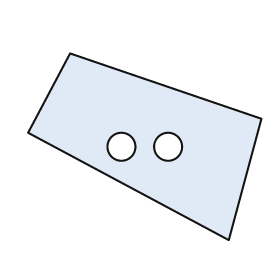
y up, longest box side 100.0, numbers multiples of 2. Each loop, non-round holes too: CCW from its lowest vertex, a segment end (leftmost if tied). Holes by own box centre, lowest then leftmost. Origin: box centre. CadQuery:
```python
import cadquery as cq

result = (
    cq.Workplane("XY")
    .moveTo(36.0, -40.0)
    .lineTo(50.0, 12.0)
    .lineTo(-32.0, 40.0)
    .lineTo(-50.0, 6.0)
    .close()
    .moveTo(-10.0, 0.0)
    .circle(6.0)
    .moveTo(10.0, 0.0)
    .circle(6.0)
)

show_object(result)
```